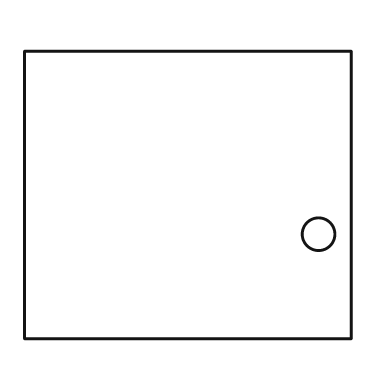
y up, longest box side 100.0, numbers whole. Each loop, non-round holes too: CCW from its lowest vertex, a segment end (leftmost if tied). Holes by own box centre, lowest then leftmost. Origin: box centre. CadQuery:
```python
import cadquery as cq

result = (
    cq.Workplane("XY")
    .moveTo(-50.0, -44.0)
    .lineTo(50.0, -44.0)
    .lineTo(50.0, 44.0)
    .lineTo(-50.0, 44.0)
    .close()
    .moveTo(40.0, -12.0)
    .circle(5.0)
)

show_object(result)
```